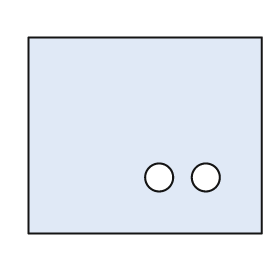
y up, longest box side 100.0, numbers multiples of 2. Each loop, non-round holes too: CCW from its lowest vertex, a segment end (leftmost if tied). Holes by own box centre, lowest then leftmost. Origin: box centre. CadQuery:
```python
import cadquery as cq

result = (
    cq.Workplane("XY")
    .moveTo(-50.0, -42.0)
    .lineTo(50.0, -42.0)
    .lineTo(50.0, 42.0)
    .lineTo(-50.0, 42.0)
    .close()
    .moveTo(6.0, -18.0)
    .circle(6.0)
    .moveTo(26.0, -18.0)
    .circle(6.0)
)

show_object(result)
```